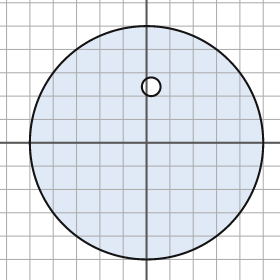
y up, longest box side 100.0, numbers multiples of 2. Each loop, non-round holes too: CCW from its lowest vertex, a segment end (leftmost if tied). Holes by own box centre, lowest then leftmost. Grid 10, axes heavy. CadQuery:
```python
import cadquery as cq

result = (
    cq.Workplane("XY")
    .moveTo(0.0, 0.0)
    .circle(50.0)
    .moveTo(2.0, 24.0)
    .circle(4.0)
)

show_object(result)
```